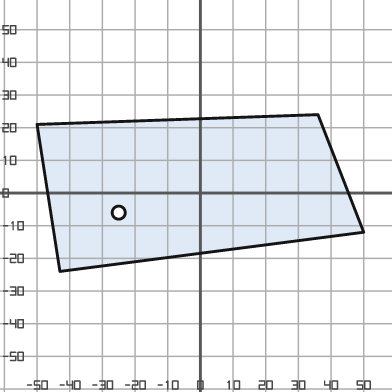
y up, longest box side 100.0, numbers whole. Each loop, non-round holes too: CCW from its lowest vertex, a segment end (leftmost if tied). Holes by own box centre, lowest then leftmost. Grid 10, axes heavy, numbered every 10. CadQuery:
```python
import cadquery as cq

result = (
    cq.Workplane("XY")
    .moveTo(-43.0, -24.0)
    .lineTo(50.0, -12.0)
    .lineTo(36.0, 24.0)
    .lineTo(-50.0, 21.0)
    .close()
    .moveTo(-25.0, -6.0)
    .circle(2.0)
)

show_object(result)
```